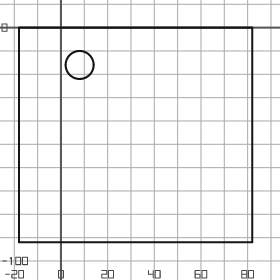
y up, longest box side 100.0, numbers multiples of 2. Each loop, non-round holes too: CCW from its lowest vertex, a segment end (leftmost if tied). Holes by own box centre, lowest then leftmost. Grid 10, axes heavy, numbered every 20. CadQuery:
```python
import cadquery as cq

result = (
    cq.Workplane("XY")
    .moveTo(-18.0, -92.0)
    .lineTo(82.0, -92.0)
    .lineTo(82.0, 0.0)
    .lineTo(-18.0, 0.0)
    .close()
    .moveTo(8.0, -16.0)
    .circle(6.0)
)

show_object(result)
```